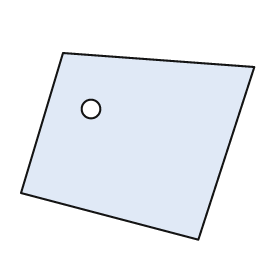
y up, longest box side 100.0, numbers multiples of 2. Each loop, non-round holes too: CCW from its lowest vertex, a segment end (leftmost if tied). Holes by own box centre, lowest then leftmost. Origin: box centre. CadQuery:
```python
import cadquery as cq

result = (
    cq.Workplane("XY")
    .moveTo(26.0, -40.0)
    .lineTo(50.0, 34.0)
    .lineTo(-32.0, 40.0)
    .lineTo(-50.0, -20.0)
    .close()
    .moveTo(-20.0, 16.0)
    .circle(4.0)
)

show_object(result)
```